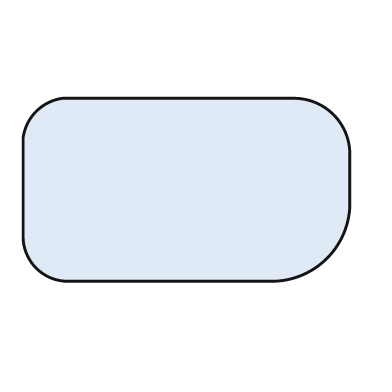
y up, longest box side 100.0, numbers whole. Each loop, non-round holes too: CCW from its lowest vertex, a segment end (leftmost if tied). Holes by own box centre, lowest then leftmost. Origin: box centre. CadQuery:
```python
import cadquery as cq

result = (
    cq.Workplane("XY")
    .moveTo(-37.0, -28.0)
    .lineTo(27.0, -28.0)
    .threePointArc((43.0, -21.0), (50.0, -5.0))
    .lineTo(50.0, 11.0)
    .threePointArc((45.0, 23.0), (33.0, 28.0))
    .lineTo(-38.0, 28.0)
    .threePointArc((-46.0, 24.0), (-50.0, 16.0))
    .lineTo(-50.0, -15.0)
    .threePointArc((-46.0, -24.0), (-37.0, -28.0))
    .close()
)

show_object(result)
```